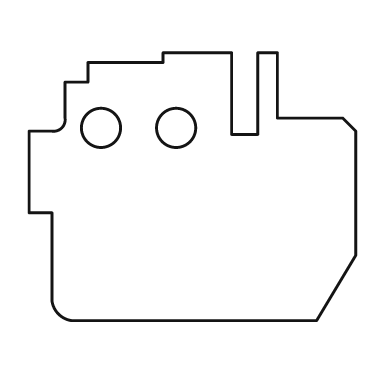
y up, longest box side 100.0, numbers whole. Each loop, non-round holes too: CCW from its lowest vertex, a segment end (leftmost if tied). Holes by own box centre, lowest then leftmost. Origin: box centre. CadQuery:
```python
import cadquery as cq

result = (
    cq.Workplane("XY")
    .moveTo(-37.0, -41.0)
    .lineTo(38.0, -41.0)
    .lineTo(50.0, -21.0)
    .lineTo(50.0, 17.0)
    .lineTo(46.0, 21.0)
    .lineTo(26.0, 21.0)
    .lineTo(26.0, 41.0)
    .lineTo(20.0, 41.0)
    .lineTo(20.0, 16.0)
    .lineTo(12.0, 16.0)
    .lineTo(12.0, 41.0)
    .lineTo(-9.0, 41.0)
    .lineTo(-9.0, 38.0)
    .lineTo(-32.0, 38.0)
    .lineTo(-32.0, 32.0)
    .lineTo(-39.0, 32.0)
    .lineTo(-39.0, 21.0)
    .threePointArc((-40.0, 18.0), (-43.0, 17.0))
    .lineTo(-50.0, 17.0)
    .lineTo(-50.0, -8.0)
    .lineTo(-43.0, -8.0)
    .lineTo(-43.0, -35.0)
    .threePointArc((-41.0, -39.0), (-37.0, -41.0))
    .close()
    .moveTo(-28.0, 18.0)
    .circle(6.0)
    .moveTo(-5.0, 18.0)
    .circle(6.0)
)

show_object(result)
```